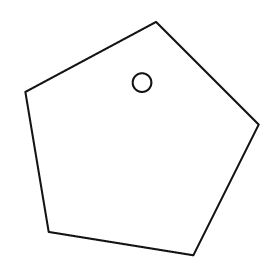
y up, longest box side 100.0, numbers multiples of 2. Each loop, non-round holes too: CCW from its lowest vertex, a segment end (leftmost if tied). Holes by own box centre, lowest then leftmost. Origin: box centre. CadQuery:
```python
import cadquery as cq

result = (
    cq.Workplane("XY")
    .moveTo(22.0, -50.0)
    .lineTo(50.0, 6.0)
    .lineTo(6.0, 50.0)
    .lineTo(-50.0, 20.0)
    .lineTo(-40.0, -40.0)
    .close()
    .moveTo(0.0, 24.0)
    .circle(4.0)
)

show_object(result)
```